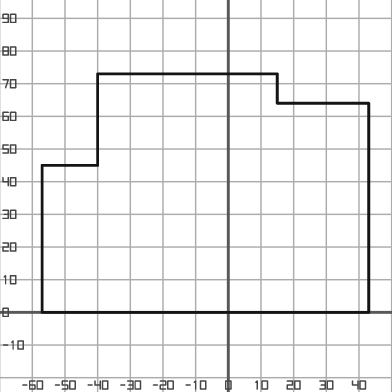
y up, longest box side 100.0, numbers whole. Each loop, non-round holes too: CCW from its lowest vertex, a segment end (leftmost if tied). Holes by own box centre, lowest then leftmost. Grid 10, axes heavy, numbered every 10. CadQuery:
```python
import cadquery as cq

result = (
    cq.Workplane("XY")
    .moveTo(-57.0, 0.0)
    .lineTo(43.0, 0.0)
    .lineTo(43.0, 64.0)
    .lineTo(15.0, 64.0)
    .lineTo(15.0, 73.0)
    .lineTo(-40.0, 73.0)
    .lineTo(-40.0, 45.0)
    .lineTo(-57.0, 45.0)
    .close()
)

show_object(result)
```